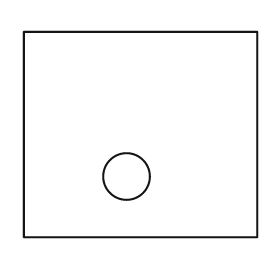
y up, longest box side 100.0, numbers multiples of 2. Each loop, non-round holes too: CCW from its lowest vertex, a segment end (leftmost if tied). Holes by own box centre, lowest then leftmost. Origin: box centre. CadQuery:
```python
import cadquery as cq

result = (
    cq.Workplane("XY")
    .moveTo(-50.0, -44.0)
    .lineTo(50.0, -44.0)
    .lineTo(50.0, 44.0)
    .lineTo(-50.0, 44.0)
    .close()
    .moveTo(-6.0, -18.0)
    .circle(10.0)
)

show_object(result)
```